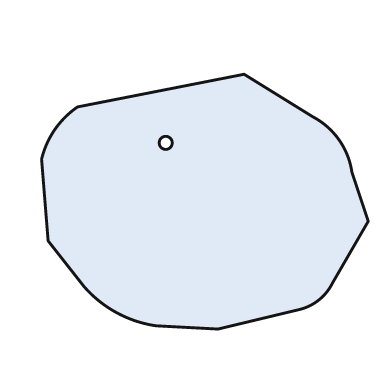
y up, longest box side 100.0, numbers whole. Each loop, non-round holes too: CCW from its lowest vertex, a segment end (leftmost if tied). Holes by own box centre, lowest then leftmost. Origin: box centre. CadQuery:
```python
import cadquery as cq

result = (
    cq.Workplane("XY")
    .moveTo(4.0, -39.0)
    .lineTo(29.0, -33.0)
    .threePointArc((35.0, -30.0), (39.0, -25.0))
    .lineTo(50.0, -6.0)
    .lineTo(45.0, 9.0)
    .threePointArc((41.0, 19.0), (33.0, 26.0))
    .lineTo(12.0, 39.0)
    .lineTo(-39.0, 29.0)
    .threePointArc((-46.0, 22.0), (-50.0, 13.0))
    .lineTo(-48.0, -12.0)
    .lineTo(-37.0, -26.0)
    .threePointArc((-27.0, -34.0), (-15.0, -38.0))
    .close()
    .moveTo(-12.0, 18.0)
    .circle(2.0)
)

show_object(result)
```